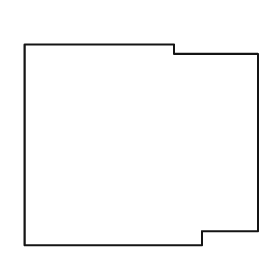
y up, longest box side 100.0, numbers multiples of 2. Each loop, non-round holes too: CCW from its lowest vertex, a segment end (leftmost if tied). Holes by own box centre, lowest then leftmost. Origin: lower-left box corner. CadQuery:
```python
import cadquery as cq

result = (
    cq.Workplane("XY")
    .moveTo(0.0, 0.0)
    .lineTo(76.0, 0.0)
    .lineTo(76.0, 6.0)
    .lineTo(100.0, 6.0)
    .lineTo(100.0, 82.0)
    .lineTo(64.0, 82.0)
    .lineTo(64.0, 86.0)
    .lineTo(0.0, 86.0)
    .close()
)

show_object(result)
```